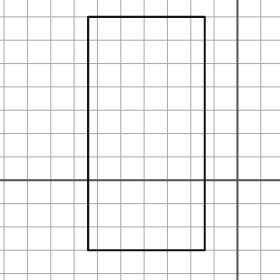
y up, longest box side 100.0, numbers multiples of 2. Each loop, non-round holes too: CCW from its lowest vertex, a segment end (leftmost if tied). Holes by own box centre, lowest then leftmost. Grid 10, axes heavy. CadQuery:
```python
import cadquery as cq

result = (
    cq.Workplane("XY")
    .moveTo(-64.0, -30.0)
    .lineTo(-14.0, -30.0)
    .lineTo(-14.0, 70.0)
    .lineTo(-64.0, 70.0)
    .close()
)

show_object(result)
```